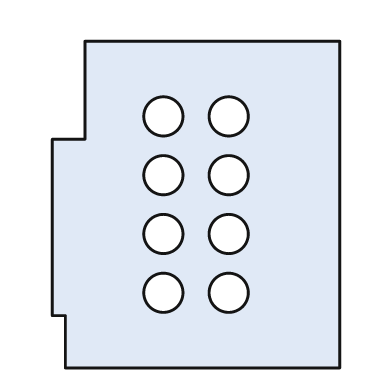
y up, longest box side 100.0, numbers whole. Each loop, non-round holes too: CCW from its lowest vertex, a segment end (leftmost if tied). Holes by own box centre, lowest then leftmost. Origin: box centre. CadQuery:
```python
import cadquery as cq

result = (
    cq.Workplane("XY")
    .moveTo(-40.0, -50.0)
    .lineTo(44.0, -50.0)
    .lineTo(44.0, 50.0)
    .lineTo(-34.0, 50.0)
    .lineTo(-34.0, 20.0)
    .lineTo(-44.0, 20.0)
    .lineTo(-44.0, -34.0)
    .lineTo(-40.0, -34.0)
    .close()
    .moveTo(-10.0, -27.0)
    .circle(6.0)
    .moveTo(10.0, -27.0)
    .circle(6.0)
    .moveTo(-10.0, -9.0)
    .circle(6.0)
    .moveTo(10.0, -9.0)
    .circle(6.0)
    .moveTo(-10.0, 9.0)
    .circle(6.0)
    .moveTo(10.0, 9.0)
    .circle(6.0)
    .moveTo(-10.0, 27.0)
    .circle(6.0)
    .moveTo(10.0, 27.0)
    .circle(6.0)
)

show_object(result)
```